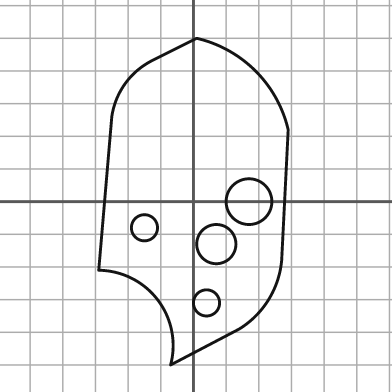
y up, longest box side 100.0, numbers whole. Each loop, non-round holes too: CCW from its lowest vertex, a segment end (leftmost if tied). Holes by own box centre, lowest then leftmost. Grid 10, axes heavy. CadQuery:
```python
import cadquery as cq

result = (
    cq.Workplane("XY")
    .moveTo(-7.0, -50.0)
    .lineTo(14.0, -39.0)
    .threePointArc((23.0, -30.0), (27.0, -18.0))
    .lineTo(29.0, 22.0)
    .threePointArc((19.0, 40.0), (1.0, 50.0))
    .lineTo(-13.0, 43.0)
    .threePointArc((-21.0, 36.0), (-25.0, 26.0))
    .lineTo(-29.0, -21.0)
    .threePointArc((-11.0, -30.0), (-7.0, -50.0))
    .close()
    .moveTo(4.0, -31.0)
    .circle(4.0)
    .moveTo(7.0, -13.0)
    .circle(6.0)
    .moveTo(-15.0, -8.0)
    .circle(4.0)
    .moveTo(17.0, 0.0)
    .circle(7.0)
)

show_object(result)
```